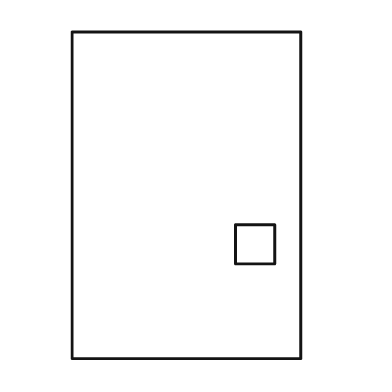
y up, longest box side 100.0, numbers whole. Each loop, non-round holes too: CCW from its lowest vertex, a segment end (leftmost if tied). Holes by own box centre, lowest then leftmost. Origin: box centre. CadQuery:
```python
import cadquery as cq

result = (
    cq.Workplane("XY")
    .moveTo(-35.0, -50.0)
    .lineTo(35.0, -50.0)
    .lineTo(35.0, 50.0)
    .lineTo(-35.0, 50.0)
    .close()
    .moveTo(15.0, -21.0)
    .lineTo(27.0, -21.0)
    .lineTo(27.0, -9.0)
    .lineTo(15.0, -9.0)
    .close()
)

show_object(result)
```